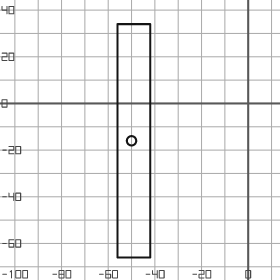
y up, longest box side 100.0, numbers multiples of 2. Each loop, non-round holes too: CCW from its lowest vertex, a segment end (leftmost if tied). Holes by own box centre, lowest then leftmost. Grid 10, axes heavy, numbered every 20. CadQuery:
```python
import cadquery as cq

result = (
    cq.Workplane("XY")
    .moveTo(-56.0, -66.0)
    .lineTo(-42.0, -66.0)
    .lineTo(-42.0, 34.0)
    .lineTo(-56.0, 34.0)
    .close()
    .moveTo(-50.0, -16.0)
    .circle(2.0)
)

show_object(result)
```